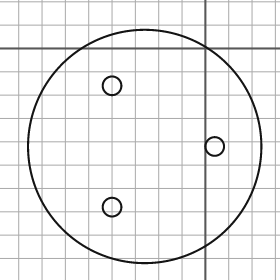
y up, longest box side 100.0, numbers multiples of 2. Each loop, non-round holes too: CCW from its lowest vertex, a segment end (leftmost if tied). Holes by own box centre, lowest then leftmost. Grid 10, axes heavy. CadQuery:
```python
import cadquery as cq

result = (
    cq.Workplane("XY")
    .moveTo(-26.0, -42.0)
    .circle(50.0)
    .moveTo(-40.0, -68.0)
    .circle(4.0)
    .moveTo(4.0, -42.0)
    .circle(4.0)
    .moveTo(-40.0, -16.0)
    .circle(4.0)
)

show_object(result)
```